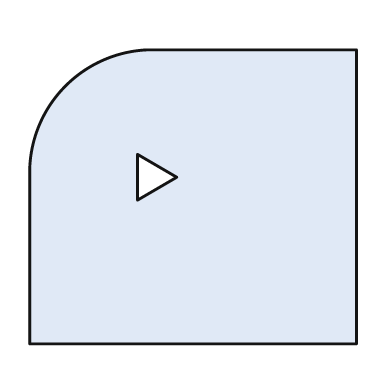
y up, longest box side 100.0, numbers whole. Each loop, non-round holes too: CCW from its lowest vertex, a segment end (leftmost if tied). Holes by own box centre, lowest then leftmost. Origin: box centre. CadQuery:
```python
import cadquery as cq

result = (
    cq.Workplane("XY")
    .moveTo(-50.0, -45.0)
    .lineTo(50.0, -45.0)
    .lineTo(50.0, 45.0)
    .lineTo(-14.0, 45.0)
    .threePointArc((-39.0, 34.0), (-50.0, 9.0))
    .close()
    .moveTo(-17.0, -1.0)
    .lineTo(-5.0, 6.0)
    .lineTo(-17.0, 13.0)
    .close()
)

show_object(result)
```